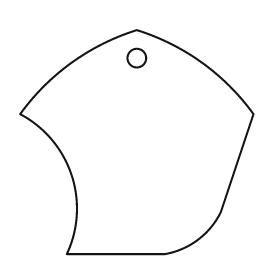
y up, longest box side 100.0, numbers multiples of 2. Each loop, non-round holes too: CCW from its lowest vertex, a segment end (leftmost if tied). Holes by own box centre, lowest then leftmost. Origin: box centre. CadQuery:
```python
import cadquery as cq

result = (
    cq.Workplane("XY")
    .moveTo(-30.0, -48.0)
    .lineTo(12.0, -48.0)
    .threePointArc((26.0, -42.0), (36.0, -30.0))
    .lineTo(50.0, 12.0)
    .threePointArc((28.0, 34.0), (0.0, 48.0))
    .threePointArc((-28.0, 34.0), (-50.0, 12.0))
    .threePointArc((-28.0, -14.0), (-30.0, -48.0))
    .close()
    .moveTo(0.0, 36.0)
    .circle(4.0)
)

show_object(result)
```